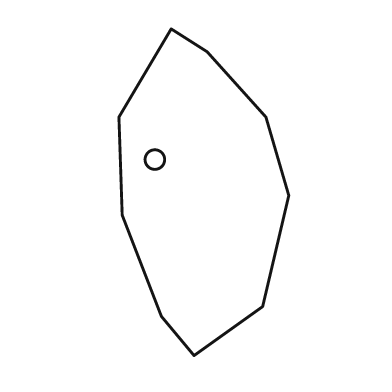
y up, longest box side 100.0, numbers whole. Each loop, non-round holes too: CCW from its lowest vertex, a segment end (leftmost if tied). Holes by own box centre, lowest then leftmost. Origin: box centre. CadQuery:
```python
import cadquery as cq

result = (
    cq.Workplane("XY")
    .moveTo(-3.0, -50.0)
    .lineTo(18.0, -35.0)
    .lineTo(26.0, -1.0)
    .lineTo(19.0, 23.0)
    .lineTo(1.0, 43.0)
    .lineTo(-10.0, 50.0)
    .lineTo(-26.0, 23.0)
    .lineTo(-25.0, -7.0)
    .lineTo(-13.0, -38.0)
    .close()
    .moveTo(-15.0, 10.0)
    .circle(3.0)
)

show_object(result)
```